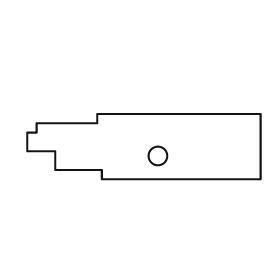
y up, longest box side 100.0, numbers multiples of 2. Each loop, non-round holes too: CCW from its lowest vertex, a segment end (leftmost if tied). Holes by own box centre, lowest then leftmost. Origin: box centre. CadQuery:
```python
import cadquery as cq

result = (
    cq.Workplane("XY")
    .moveTo(-18.0, -14.0)
    .lineTo(50.0, -14.0)
    .lineTo(50.0, 14.0)
    .lineTo(-20.0, 14.0)
    .lineTo(-20.0, 10.0)
    .lineTo(-46.0, 10.0)
    .lineTo(-46.0, 6.0)
    .lineTo(-50.0, 6.0)
    .lineTo(-50.0, -2.0)
    .lineTo(-38.0, -2.0)
    .lineTo(-38.0, -10.0)
    .lineTo(-18.0, -10.0)
    .close()
    .moveTo(6.0, -4.0)
    .circle(4.0)
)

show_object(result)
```